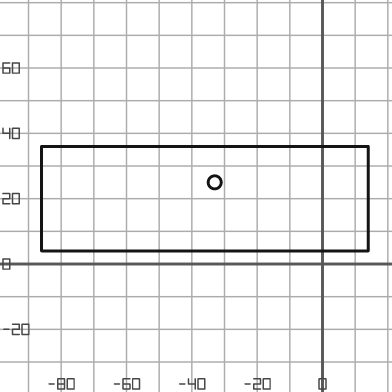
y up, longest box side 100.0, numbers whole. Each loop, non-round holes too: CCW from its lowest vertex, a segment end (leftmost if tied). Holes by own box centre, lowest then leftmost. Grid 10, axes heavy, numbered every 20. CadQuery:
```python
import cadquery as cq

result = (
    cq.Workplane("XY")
    .moveTo(-86.0, 4.0)
    .lineTo(14.0, 4.0)
    .lineTo(14.0, 36.0)
    .lineTo(-86.0, 36.0)
    .close()
    .moveTo(-33.0, 25.0)
    .circle(2.0)
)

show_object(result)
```